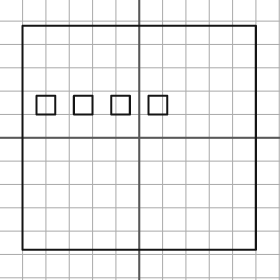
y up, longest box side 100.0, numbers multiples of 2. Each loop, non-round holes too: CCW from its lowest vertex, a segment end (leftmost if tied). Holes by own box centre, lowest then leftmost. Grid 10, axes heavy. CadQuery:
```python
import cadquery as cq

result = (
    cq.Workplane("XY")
    .moveTo(-50.0, -48.0)
    .lineTo(50.0, -48.0)
    .lineTo(50.0, 48.0)
    .lineTo(-50.0, 48.0)
    .close()
    .moveTo(-44.0, 10.0)
    .lineTo(-36.0, 10.0)
    .lineTo(-36.0, 18.0)
    .lineTo(-44.0, 18.0)
    .close()
    .moveTo(-28.0, 10.0)
    .lineTo(-20.0, 10.0)
    .lineTo(-20.0, 18.0)
    .lineTo(-28.0, 18.0)
    .close()
    .moveTo(-12.0, 10.0)
    .lineTo(-4.0, 10.0)
    .lineTo(-4.0, 18.0)
    .lineTo(-12.0, 18.0)
    .close()
    .moveTo(4.0, 10.0)
    .lineTo(12.0, 10.0)
    .lineTo(12.0, 18.0)
    .lineTo(4.0, 18.0)
    .close()
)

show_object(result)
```